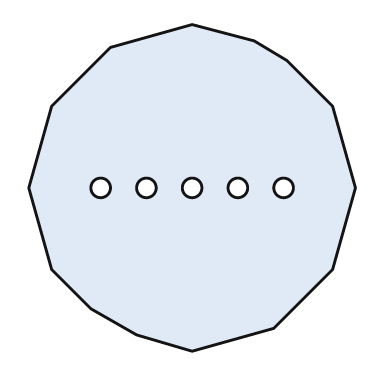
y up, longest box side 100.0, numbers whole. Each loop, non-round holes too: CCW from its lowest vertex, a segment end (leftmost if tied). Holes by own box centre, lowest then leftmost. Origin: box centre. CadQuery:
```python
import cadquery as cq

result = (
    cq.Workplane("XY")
    .moveTo(0.0, -50.0)
    .lineTo(25.0, -43.0)
    .lineTo(43.0, -25.0)
    .lineTo(50.0, 0.0)
    .lineTo(43.0, 25.0)
    .lineTo(29.0, 39.0)
    .lineTo(19.0, 45.0)
    .lineTo(0.0, 50.0)
    .lineTo(-25.0, 43.0)
    .lineTo(-43.0, 25.0)
    .lineTo(-50.0, 0.0)
    .lineTo(-43.0, -25.0)
    .lineTo(-31.0, -37.0)
    .lineTo(-17.0, -45.0)
    .close()
    .moveTo(-28.0, 0.0)
    .circle(3.0)
    .moveTo(-14.0, 0.0)
    .circle(3.0)
    .moveTo(0.0, 0.0)
    .circle(3.0)
    .moveTo(14.0, 0.0)
    .circle(3.0)
    .moveTo(28.0, 0.0)
    .circle(3.0)
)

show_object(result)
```